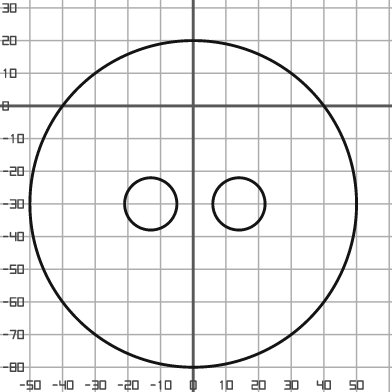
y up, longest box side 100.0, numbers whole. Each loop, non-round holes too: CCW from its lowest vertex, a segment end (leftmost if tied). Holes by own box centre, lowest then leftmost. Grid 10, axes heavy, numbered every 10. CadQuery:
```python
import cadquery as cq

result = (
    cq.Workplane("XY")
    .moveTo(0.0, -30.0)
    .circle(50.0)
    .moveTo(-13.0, -30.0)
    .circle(8.0)
    .moveTo(14.0, -30.0)
    .circle(8.0)
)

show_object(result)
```